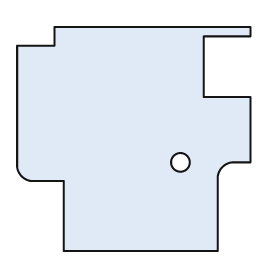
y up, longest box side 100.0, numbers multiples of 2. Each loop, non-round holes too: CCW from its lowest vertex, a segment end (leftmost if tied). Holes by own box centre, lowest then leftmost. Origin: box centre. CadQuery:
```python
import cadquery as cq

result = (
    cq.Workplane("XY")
    .moveTo(-30.0, -48.0)
    .lineTo(36.0, -48.0)
    .lineTo(36.0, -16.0)
    .threePointArc((38.0, -12.0), (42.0, -10.0))
    .lineTo(50.0, -10.0)
    .lineTo(50.0, 18.0)
    .lineTo(30.0, 18.0)
    .lineTo(30.0, 44.0)
    .lineTo(50.0, 44.0)
    .lineTo(50.0, 48.0)
    .lineTo(-34.0, 48.0)
    .lineTo(-34.0, 40.0)
    .lineTo(-50.0, 40.0)
    .lineTo(-50.0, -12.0)
    .threePointArc((-48.0, -16.0), (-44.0, -18.0))
    .lineTo(-30.0, -18.0)
    .close()
    .moveTo(20.0, -10.0)
    .circle(4.0)
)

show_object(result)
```